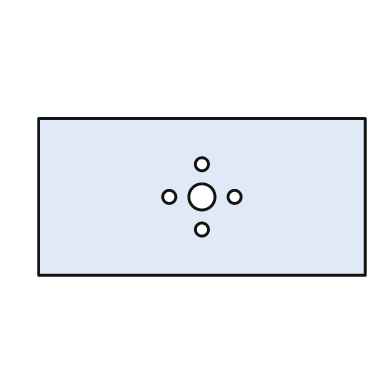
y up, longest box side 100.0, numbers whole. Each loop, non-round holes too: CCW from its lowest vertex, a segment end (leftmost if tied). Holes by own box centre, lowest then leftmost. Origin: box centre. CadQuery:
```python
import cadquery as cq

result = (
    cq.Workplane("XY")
    .moveTo(-50.0, -24.0)
    .lineTo(50.0, -24.0)
    .lineTo(50.0, 24.0)
    .lineTo(-50.0, 24.0)
    .close()
    .moveTo(0.0, -10.0)
    .circle(2.0)
    .moveTo(-10.0, 0.0)
    .circle(2.0)
    .moveTo(0.0, 0.0)
    .circle(4.0)
    .moveTo(10.0, 0.0)
    .circle(2.0)
    .moveTo(0.0, 10.0)
    .circle(2.0)
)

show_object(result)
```